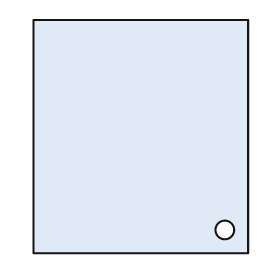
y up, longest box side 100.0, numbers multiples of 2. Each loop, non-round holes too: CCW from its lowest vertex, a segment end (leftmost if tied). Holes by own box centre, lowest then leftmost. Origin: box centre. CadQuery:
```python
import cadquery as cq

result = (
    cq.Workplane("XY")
    .moveTo(-46.0, -50.0)
    .lineTo(46.0, -50.0)
    .lineTo(46.0, 50.0)
    .lineTo(-46.0, 50.0)
    .close()
    .moveTo(36.0, -40.0)
    .circle(4.0)
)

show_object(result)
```